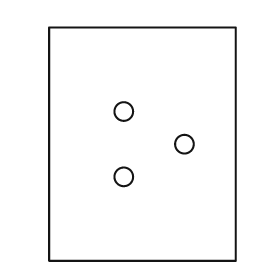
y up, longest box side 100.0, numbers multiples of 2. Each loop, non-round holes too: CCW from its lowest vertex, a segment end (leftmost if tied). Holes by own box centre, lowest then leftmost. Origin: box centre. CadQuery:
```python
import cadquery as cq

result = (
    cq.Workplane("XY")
    .moveTo(-40.0, -50.0)
    .lineTo(40.0, -50.0)
    .lineTo(40.0, 50.0)
    .lineTo(-40.0, 50.0)
    .close()
    .moveTo(-8.0, -14.0)
    .circle(4.0)
    .moveTo(18.0, 0.0)
    .circle(4.0)
    .moveTo(-8.0, 14.0)
    .circle(4.0)
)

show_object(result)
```